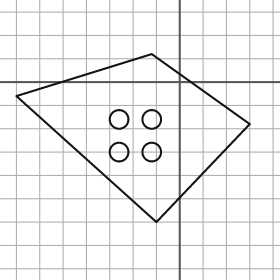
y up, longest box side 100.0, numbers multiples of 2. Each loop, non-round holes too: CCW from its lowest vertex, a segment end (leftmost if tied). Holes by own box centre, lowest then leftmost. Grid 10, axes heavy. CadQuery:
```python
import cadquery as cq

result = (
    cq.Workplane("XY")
    .moveTo(-10.0, -60.0)
    .lineTo(30.0, -18.0)
    .lineTo(-12.0, 12.0)
    .lineTo(-70.0, -6.0)
    .close()
    .moveTo(-26.0, -30.0)
    .circle(4.0)
    .moveTo(-12.0, -30.0)
    .circle(4.0)
    .moveTo(-26.0, -16.0)
    .circle(4.0)
    .moveTo(-12.0, -16.0)
    .circle(4.0)
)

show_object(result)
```